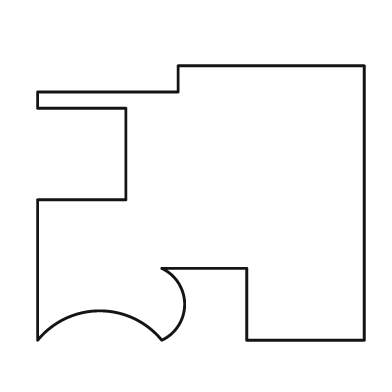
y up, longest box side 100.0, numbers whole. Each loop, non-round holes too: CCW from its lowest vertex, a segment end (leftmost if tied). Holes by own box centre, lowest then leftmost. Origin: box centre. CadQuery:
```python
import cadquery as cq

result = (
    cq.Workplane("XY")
    .moveTo(-50.0, -42.0)
    .threePointArc((-31.0, -33.0), (-12.0, -42.0))
    .threePointArc((-5.0, -31.0), (-12.0, -20.0))
    .lineTo(14.0, -20.0)
    .lineTo(14.0, -42.0)
    .lineTo(50.0, -42.0)
    .lineTo(50.0, 42.0)
    .lineTo(-7.0, 42.0)
    .lineTo(-7.0, 34.0)
    .lineTo(-50.0, 34.0)
    .lineTo(-50.0, 29.0)
    .lineTo(-23.0, 29.0)
    .lineTo(-23.0, 1.0)
    .lineTo(-50.0, 1.0)
    .close()
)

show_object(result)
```